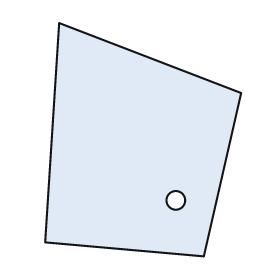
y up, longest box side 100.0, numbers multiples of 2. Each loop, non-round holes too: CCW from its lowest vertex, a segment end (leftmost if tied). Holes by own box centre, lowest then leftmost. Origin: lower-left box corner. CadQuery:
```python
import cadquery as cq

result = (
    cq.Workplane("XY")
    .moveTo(68.0, 0.0)
    .lineTo(84.0, 70.0)
    .lineTo(6.0, 100.0)
    .lineTo(0.0, 6.0)
    .close()
    .moveTo(56.0, 24.0)
    .circle(4.0)
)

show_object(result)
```